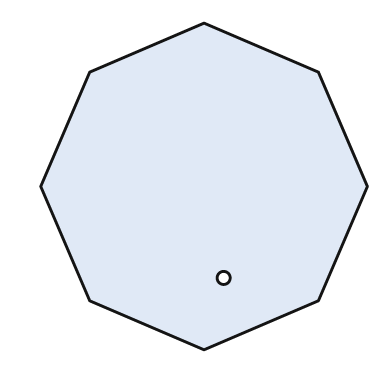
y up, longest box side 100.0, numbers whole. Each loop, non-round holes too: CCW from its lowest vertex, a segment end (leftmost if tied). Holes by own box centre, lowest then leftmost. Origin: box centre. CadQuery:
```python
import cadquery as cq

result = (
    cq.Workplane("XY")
    .moveTo(0.0, -50.0)
    .lineTo(35.0, -35.0)
    .lineTo(50.0, 0.0)
    .lineTo(35.0, 35.0)
    .lineTo(0.0, 50.0)
    .lineTo(-35.0, 35.0)
    .lineTo(-50.0, 0.0)
    .lineTo(-35.0, -35.0)
    .close()
    .moveTo(6.0, -28.0)
    .circle(2.0)
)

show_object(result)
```